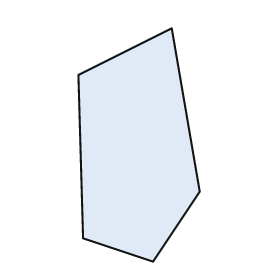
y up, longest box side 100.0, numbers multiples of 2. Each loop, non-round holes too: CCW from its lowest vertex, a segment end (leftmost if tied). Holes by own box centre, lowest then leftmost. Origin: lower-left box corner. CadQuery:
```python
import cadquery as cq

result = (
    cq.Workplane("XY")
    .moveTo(32.0, 0.0)
    .lineTo(52.0, 30.0)
    .lineTo(40.0, 100.0)
    .lineTo(0.0, 80.0)
    .lineTo(2.0, 10.0)
    .close()
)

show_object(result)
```